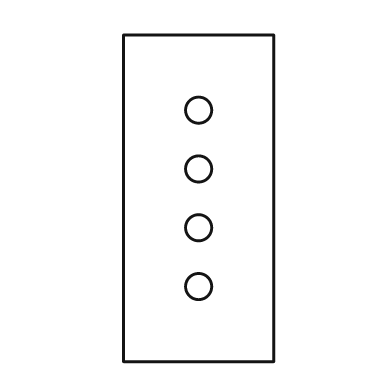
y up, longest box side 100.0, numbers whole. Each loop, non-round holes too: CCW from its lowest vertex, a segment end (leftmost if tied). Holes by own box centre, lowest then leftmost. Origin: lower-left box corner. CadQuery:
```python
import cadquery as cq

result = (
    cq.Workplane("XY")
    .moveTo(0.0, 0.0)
    .lineTo(46.0, 0.0)
    .lineTo(46.0, 100.0)
    .lineTo(0.0, 100.0)
    .close()
    .moveTo(23.0, 23.0)
    .circle(4.0)
    .moveTo(23.0, 41.0)
    .circle(4.0)
    .moveTo(23.0, 59.0)
    .circle(4.0)
    .moveTo(23.0, 77.0)
    .circle(4.0)
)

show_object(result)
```